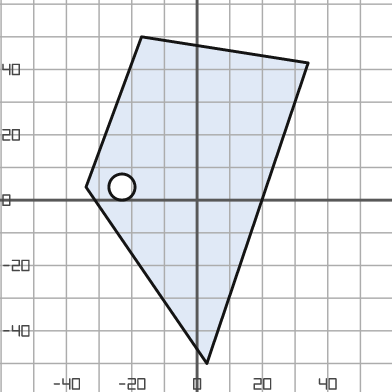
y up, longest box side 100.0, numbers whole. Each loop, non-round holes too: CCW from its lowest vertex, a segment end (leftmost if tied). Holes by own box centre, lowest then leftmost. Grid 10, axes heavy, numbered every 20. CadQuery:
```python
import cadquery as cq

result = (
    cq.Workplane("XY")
    .moveTo(3.0, -50.0)
    .lineTo(34.0, 42.0)
    .lineTo(-17.0, 50.0)
    .lineTo(-34.0, 4.0)
    .close()
    .moveTo(-23.0, 4.0)
    .circle(4.0)
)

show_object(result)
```